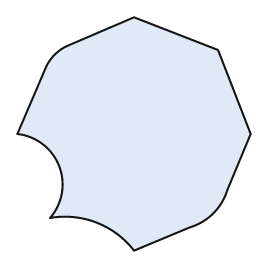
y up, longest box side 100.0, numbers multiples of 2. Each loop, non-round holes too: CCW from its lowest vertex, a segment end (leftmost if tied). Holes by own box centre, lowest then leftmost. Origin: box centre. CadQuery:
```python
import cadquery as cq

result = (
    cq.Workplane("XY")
    .moveTo(0.0, -50.0)
    .lineTo(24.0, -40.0)
    .threePointArc((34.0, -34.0), (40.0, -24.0))
    .lineTo(50.0, 0.0)
    .lineTo(36.0, 36.0)
    .lineTo(0.0, 50.0)
    .lineTo(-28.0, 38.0)
    .threePointArc((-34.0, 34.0), (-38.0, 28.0))
    .lineTo(-50.0, 0.0)
    .threePointArc((-32.0, -14.0), (-36.0, -36.0))
    .threePointArc((-16.0, -38.0), (0.0, -50.0))
    .close()
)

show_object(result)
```